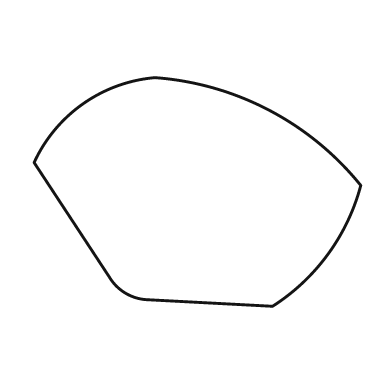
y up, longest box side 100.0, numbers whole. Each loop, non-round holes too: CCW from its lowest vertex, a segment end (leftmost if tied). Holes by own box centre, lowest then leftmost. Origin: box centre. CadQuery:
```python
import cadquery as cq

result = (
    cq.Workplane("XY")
    .moveTo(23.0, -35.0)
    .threePointArc((40.0, -19.0), (50.0, 2.0))
    .threePointArc((22.0, 25.0), (-13.0, 35.0))
    .threePointArc((-35.0, 27.0), (-50.0, 9.0))
    .lineTo(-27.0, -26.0)
    .threePointArc((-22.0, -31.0), (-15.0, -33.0))
    .close()
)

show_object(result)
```